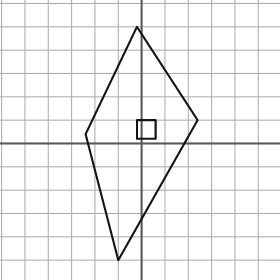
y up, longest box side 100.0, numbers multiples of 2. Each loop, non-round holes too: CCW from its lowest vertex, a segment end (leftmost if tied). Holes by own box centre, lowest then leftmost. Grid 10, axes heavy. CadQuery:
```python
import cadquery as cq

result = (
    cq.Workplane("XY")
    .moveTo(-10.0, -50.0)
    .lineTo(24.0, 10.0)
    .lineTo(-2.0, 50.0)
    .lineTo(-24.0, 4.0)
    .close()
    .moveTo(-2.0, 2.0)
    .lineTo(6.0, 2.0)
    .lineTo(6.0, 10.0)
    .lineTo(-2.0, 10.0)
    .close()
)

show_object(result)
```